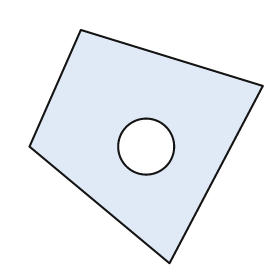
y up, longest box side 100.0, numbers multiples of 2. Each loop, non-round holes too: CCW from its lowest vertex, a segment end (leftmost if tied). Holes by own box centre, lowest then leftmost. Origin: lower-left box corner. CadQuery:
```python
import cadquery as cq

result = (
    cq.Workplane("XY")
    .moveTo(60.0, 0.0)
    .lineTo(100.0, 76.0)
    .lineTo(22.0, 100.0)
    .lineTo(0.0, 50.0)
    .close()
    .moveTo(50.0, 50.0)
    .circle(12.0)
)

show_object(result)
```